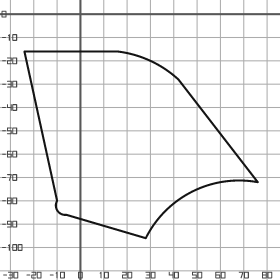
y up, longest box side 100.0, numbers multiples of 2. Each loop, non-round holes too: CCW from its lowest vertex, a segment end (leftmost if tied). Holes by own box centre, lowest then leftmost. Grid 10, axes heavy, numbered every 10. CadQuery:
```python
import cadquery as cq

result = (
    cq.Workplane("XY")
    .moveTo(28.0, -96.0)
    .threePointArc((48.0, -76.0), (76.0, -72.0))
    .lineTo(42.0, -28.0)
    .threePointArc((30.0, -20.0), (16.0, -16.0))
    .lineTo(-24.0, -16.0)
    .lineTo(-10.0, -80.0)
    .threePointArc((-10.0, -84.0), (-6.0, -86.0))
    .close()
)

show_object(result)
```